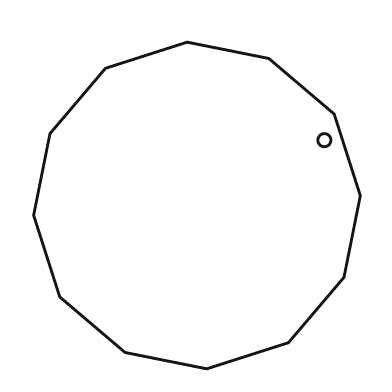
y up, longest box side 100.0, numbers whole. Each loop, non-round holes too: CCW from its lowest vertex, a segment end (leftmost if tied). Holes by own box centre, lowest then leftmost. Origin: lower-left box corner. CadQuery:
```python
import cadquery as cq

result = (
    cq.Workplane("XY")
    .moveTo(53.0, 0.0)
    .lineTo(78.0, 8.0)
    .lineTo(95.0, 28.0)
    .lineTo(100.0, 53.0)
    .lineTo(92.0, 78.0)
    .lineTo(72.0, 95.0)
    .lineTo(47.0, 100.0)
    .lineTo(22.0, 92.0)
    .lineTo(5.0, 72.0)
    .lineTo(0.0, 47.0)
    .lineTo(8.0, 22.0)
    .lineTo(28.0, 5.0)
    .close()
    .moveTo(89.0, 70.0)
    .circle(2.0)
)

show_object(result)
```